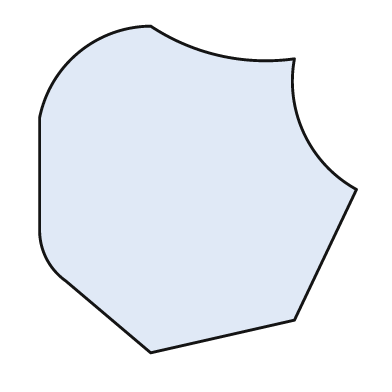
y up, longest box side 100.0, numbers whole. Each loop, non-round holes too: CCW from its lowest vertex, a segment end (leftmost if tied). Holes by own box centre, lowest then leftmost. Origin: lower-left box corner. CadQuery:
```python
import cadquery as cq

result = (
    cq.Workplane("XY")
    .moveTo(34.0, 0.0)
    .lineTo(78.0, 10.0)
    .lineTo(97.0, 50.0)
    .threePointArc((81.0, 67.0), (78.0, 90.0))
    .threePointArc((55.0, 91.0), (34.0, 100.0))
    .threePointArc((12.0, 92.0), (0.0, 72.0))
    .lineTo(0.0, 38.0)
    .threePointArc((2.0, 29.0), (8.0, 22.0))
    .close()
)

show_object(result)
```